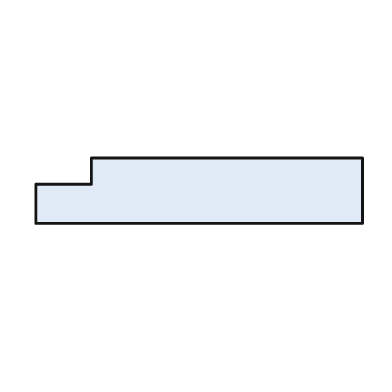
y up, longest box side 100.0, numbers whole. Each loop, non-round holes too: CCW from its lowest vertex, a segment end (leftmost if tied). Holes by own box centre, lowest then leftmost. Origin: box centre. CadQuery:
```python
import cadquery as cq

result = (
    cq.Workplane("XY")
    .moveTo(-50.0, -10.0)
    .lineTo(50.0, -10.0)
    .lineTo(50.0, 10.0)
    .lineTo(-33.0, 10.0)
    .lineTo(-33.0, 2.0)
    .lineTo(-50.0, 2.0)
    .close()
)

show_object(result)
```